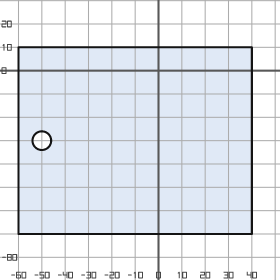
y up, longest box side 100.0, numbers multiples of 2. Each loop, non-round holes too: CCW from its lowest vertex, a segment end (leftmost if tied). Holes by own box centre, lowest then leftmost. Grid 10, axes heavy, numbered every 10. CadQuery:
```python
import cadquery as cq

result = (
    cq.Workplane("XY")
    .moveTo(-60.0, -70.0)
    .lineTo(40.0, -70.0)
    .lineTo(40.0, 10.0)
    .lineTo(-60.0, 10.0)
    .close()
    .moveTo(-50.0, -30.0)
    .circle(4.0)
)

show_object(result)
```